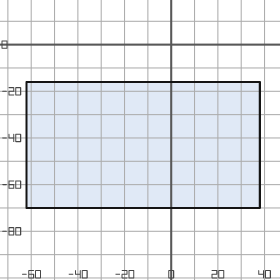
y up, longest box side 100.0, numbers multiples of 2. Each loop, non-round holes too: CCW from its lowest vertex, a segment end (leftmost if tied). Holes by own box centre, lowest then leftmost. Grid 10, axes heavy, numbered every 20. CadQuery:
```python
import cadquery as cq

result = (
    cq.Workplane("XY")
    .moveTo(-62.0, -70.0)
    .lineTo(38.0, -70.0)
    .lineTo(38.0, -16.0)
    .lineTo(-62.0, -16.0)
    .close()
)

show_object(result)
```